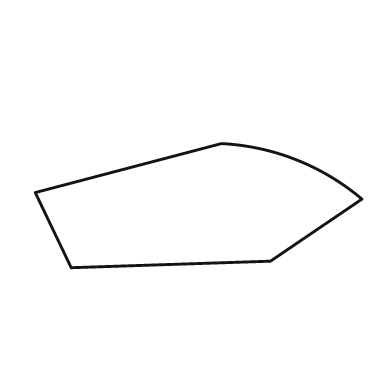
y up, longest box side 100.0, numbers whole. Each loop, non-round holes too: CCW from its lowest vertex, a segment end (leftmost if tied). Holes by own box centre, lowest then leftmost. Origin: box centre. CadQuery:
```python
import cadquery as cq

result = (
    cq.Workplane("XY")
    .moveTo(-39.0, -19.0)
    .lineTo(22.0, -17.0)
    .lineTo(50.0, 2.0)
    .threePointArc((30.0, 14.0), (7.0, 19.0))
    .lineTo(-50.0, 4.0)
    .close()
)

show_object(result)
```